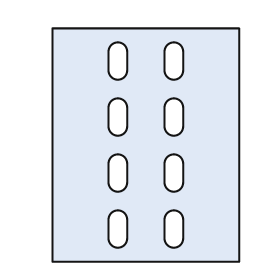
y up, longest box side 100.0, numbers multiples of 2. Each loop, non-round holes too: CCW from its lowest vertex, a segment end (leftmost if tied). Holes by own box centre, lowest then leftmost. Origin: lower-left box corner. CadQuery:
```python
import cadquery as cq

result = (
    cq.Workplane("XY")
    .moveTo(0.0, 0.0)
    .lineTo(80.0, 0.0)
    .lineTo(80.0, 100.0)
    .lineTo(0.0, 100.0)
    .close()
    .moveTo(24.0, 10.0)
    .threePointArc((28.0, 6.0), (32.0, 10.0))
    .lineTo(32.0, 18.0)
    .threePointArc((28.0, 22.0), (24.0, 18.0))
    .close()
    .moveTo(48.0, 10.0)
    .threePointArc((52.0, 6.0), (56.0, 10.0))
    .lineTo(56.0, 18.0)
    .threePointArc((52.0, 22.0), (48.0, 18.0))
    .close()
    .moveTo(24.0, 34.0)
    .threePointArc((28.0, 30.0), (32.0, 34.0))
    .lineTo(32.0, 42.0)
    .threePointArc((28.0, 46.0), (24.0, 42.0))
    .close()
    .moveTo(48.0, 34.0)
    .threePointArc((52.0, 30.0), (56.0, 34.0))
    .lineTo(56.0, 42.0)
    .threePointArc((52.0, 46.0), (48.0, 42.0))
    .close()
    .moveTo(24.0, 58.0)
    .threePointArc((28.0, 54.0), (32.0, 58.0))
    .lineTo(32.0, 66.0)
    .threePointArc((28.0, 70.0), (24.0, 66.0))
    .close()
    .moveTo(48.0, 58.0)
    .threePointArc((52.0, 54.0), (56.0, 58.0))
    .lineTo(56.0, 66.0)
    .threePointArc((52.0, 70.0), (48.0, 66.0))
    .close()
    .moveTo(24.0, 82.0)
    .threePointArc((28.0, 78.0), (32.0, 82.0))
    .lineTo(32.0, 90.0)
    .threePointArc((28.0, 94.0), (24.0, 90.0))
    .close()
    .moveTo(48.0, 82.0)
    .threePointArc((52.0, 78.0), (56.0, 82.0))
    .lineTo(56.0, 90.0)
    .threePointArc((52.0, 94.0), (48.0, 90.0))
    .close()
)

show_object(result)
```